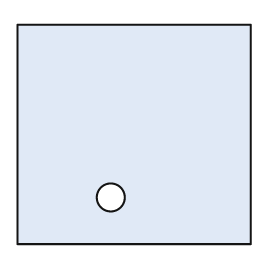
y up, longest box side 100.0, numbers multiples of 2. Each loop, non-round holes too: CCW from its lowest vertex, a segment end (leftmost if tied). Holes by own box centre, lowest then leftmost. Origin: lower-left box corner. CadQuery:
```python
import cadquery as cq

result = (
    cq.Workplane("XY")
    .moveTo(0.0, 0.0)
    .lineTo(100.0, 0.0)
    .lineTo(100.0, 94.0)
    .lineTo(0.0, 94.0)
    .close()
    .moveTo(40.0, 20.0)
    .circle(6.0)
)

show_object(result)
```